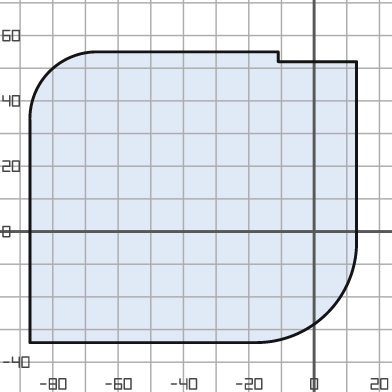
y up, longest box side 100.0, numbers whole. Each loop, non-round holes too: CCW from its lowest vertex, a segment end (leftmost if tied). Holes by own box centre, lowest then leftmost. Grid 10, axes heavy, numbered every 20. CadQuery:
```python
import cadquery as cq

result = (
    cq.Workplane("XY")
    .moveTo(-87.0, -34.0)
    .lineTo(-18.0, -34.0)
    .threePointArc((4.0, -25.0), (13.0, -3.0))
    .lineTo(13.0, 52.0)
    .lineTo(-11.0, 52.0)
    .lineTo(-11.0, 55.0)
    .lineTo(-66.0, 55.0)
    .threePointArc((-81.0, 49.0), (-87.0, 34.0))
    .close()
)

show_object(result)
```